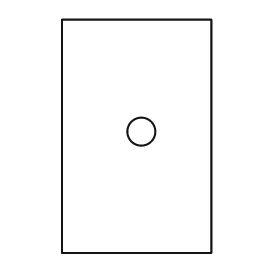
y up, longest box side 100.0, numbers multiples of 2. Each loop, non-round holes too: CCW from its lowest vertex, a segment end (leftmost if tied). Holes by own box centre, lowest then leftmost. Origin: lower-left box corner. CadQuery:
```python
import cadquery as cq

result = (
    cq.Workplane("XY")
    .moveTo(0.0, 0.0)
    .lineTo(64.0, 0.0)
    .lineTo(64.0, 100.0)
    .lineTo(0.0, 100.0)
    .close()
    .moveTo(34.0, 52.0)
    .circle(6.0)
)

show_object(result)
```